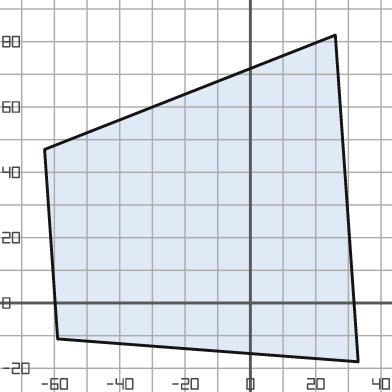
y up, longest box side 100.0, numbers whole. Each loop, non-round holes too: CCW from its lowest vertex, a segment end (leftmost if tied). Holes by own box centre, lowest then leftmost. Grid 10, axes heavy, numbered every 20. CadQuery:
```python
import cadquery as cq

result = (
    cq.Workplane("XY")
    .moveTo(33.0, -18.0)
    .lineTo(26.0, 82.0)
    .lineTo(-63.0, 47.0)
    .lineTo(-59.0, -11.0)
    .close()
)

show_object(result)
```